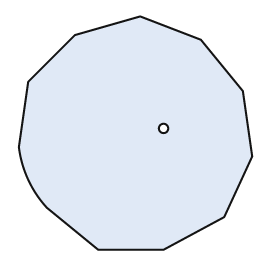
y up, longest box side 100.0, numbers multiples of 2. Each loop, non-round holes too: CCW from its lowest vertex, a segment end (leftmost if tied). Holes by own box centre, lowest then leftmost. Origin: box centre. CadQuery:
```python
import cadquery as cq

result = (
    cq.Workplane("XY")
    .moveTo(-16.0, -50.0)
    .lineTo(12.0, -50.0)
    .lineTo(38.0, -36.0)
    .lineTo(50.0, -10.0)
    .lineTo(46.0, 18.0)
    .lineTo(28.0, 40.0)
    .lineTo(2.0, 50.0)
    .lineTo(-26.0, 42.0)
    .lineTo(-46.0, 22.0)
    .lineTo(-50.0, -6.0)
    .threePointArc((-46.0, -20.0), (-38.0, -32.0))
    .close()
    .moveTo(12.0, 2.0)
    .circle(2.0)
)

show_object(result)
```